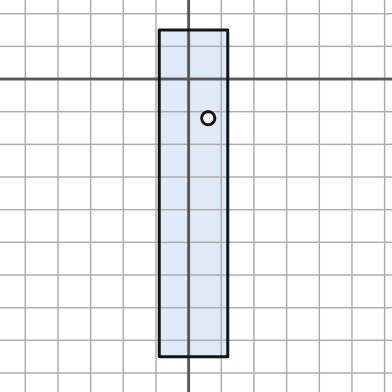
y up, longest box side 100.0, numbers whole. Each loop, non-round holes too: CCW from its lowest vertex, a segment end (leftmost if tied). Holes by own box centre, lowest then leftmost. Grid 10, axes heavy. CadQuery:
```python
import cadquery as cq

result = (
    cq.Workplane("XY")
    .moveTo(-9.0, -85.0)
    .lineTo(12.0, -85.0)
    .lineTo(12.0, 15.0)
    .lineTo(-9.0, 15.0)
    .close()
    .moveTo(6.0, -12.0)
    .circle(2.0)
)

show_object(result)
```